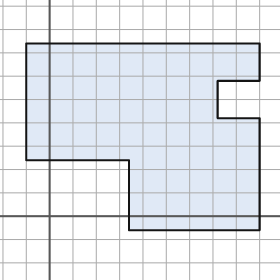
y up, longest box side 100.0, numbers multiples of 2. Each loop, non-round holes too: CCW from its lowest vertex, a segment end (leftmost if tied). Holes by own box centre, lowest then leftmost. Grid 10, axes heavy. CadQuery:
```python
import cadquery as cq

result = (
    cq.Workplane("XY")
    .moveTo(34.0, -6.0)
    .lineTo(90.0, -6.0)
    .lineTo(90.0, 42.0)
    .lineTo(72.0, 42.0)
    .lineTo(72.0, 58.0)
    .lineTo(90.0, 58.0)
    .lineTo(90.0, 74.0)
    .lineTo(-10.0, 74.0)
    .lineTo(-10.0, 24.0)
    .lineTo(34.0, 24.0)
    .close()
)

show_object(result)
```